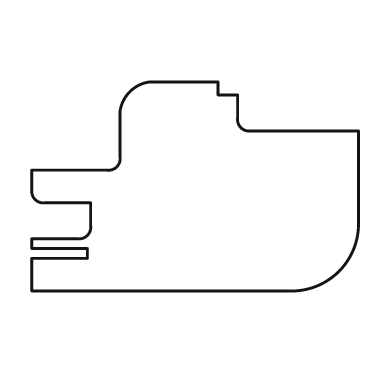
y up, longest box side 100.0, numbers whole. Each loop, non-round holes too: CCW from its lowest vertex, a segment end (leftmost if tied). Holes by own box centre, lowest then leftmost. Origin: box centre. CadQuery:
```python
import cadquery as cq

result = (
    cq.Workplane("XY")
    .moveTo(-50.0, -32.0)
    .lineTo(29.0, -32.0)
    .threePointArc((44.0, -26.0), (50.0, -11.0))
    .lineTo(50.0, 17.0)
    .lineTo(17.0, 17.0)
    .threePointArc((14.0, 18.0), (13.0, 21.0))
    .lineTo(13.0, 28.0)
    .lineTo(7.0, 28.0)
    .lineTo(7.0, 32.0)
    .lineTo(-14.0, 32.0)
    .threePointArc((-20.0, 29.0), (-23.0, 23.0))
    .lineTo(-23.0, 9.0)
    .threePointArc((-24.0, 6.0), (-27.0, 5.0))
    .lineTo(-50.0, 5.0)
    .lineTo(-50.0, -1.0)
    .threePointArc((-49.0, -4.0), (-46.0, -5.0))
    .lineTo(-32.0, -5.0)
    .lineTo(-32.0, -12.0)
    .threePointArc((-33.0, -15.0), (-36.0, -16.0))
    .lineTo(-50.0, -16.0)
    .lineTo(-50.0, -19.0)
    .lineTo(-33.0, -19.0)
    .lineTo(-33.0, -22.0)
    .lineTo(-50.0, -22.0)
    .close()
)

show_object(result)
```